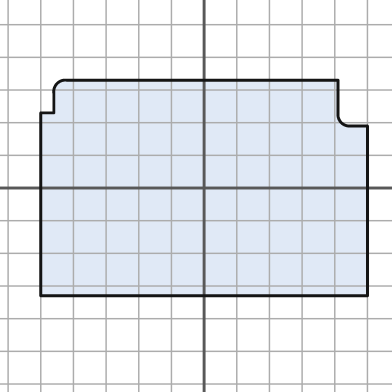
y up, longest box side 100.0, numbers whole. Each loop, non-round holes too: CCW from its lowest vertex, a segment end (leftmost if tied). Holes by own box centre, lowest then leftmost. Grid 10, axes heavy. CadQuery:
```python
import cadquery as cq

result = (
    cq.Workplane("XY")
    .moveTo(-50.0, -33.0)
    .lineTo(50.0, -33.0)
    .lineTo(50.0, 19.0)
    .lineTo(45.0, 19.0)
    .threePointArc((42.0, 20.0), (41.0, 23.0))
    .lineTo(41.0, 33.0)
    .lineTo(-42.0, 33.0)
    .threePointArc((-45.0, 32.0), (-46.0, 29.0))
    .lineTo(-46.0, 23.0)
    .lineTo(-50.0, 23.0)
    .close()
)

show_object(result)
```